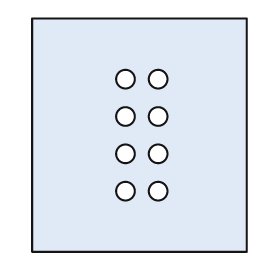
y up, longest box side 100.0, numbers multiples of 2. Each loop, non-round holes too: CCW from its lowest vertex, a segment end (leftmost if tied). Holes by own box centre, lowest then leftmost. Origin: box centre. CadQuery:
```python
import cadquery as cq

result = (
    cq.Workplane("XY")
    .moveTo(-46.0, -50.0)
    .lineTo(46.0, -50.0)
    .lineTo(46.0, 50.0)
    .lineTo(-46.0, 50.0)
    .close()
    .moveTo(-6.0, -24.0)
    .circle(4.0)
    .moveTo(8.0, -24.0)
    .circle(4.0)
    .moveTo(-6.0, -8.0)
    .circle(4.0)
    .moveTo(8.0, -8.0)
    .circle(4.0)
    .moveTo(-6.0, 8.0)
    .circle(4.0)
    .moveTo(8.0, 8.0)
    .circle(4.0)
    .moveTo(-6.0, 24.0)
    .circle(4.0)
    .moveTo(8.0, 24.0)
    .circle(4.0)
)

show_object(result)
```